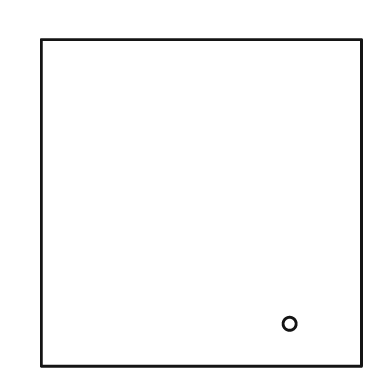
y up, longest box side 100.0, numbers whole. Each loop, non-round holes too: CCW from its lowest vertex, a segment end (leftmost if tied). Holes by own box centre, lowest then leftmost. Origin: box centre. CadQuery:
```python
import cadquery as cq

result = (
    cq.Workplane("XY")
    .moveTo(-49.0, -50.0)
    .lineTo(49.0, -50.0)
    .lineTo(49.0, 50.0)
    .lineTo(-49.0, 50.0)
    .close()
    .moveTo(27.0, -37.0)
    .circle(2.0)
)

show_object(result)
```